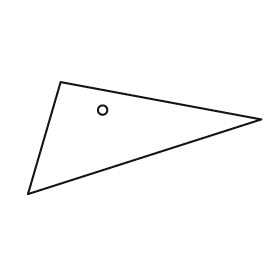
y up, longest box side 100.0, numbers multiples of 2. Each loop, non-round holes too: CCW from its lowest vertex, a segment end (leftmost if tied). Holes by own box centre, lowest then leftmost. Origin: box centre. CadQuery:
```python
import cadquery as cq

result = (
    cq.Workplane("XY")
    .moveTo(-50.0, -24.0)
    .lineTo(50.0, 8.0)
    .lineTo(-36.0, 24.0)
    .close()
    .moveTo(-18.0, 12.0)
    .circle(2.0)
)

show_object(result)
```